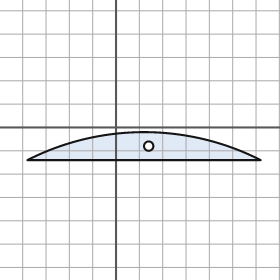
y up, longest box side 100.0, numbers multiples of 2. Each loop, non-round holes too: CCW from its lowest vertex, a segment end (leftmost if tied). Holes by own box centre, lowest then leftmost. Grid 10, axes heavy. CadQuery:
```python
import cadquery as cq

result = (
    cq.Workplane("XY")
    .moveTo(-38.0, -14.0)
    .lineTo(62.0, -14.0)
    .threePointArc((12.0, -2.0), (-38.0, -14.0))
    .close()
    .moveTo(14.0, -8.0)
    .circle(2.0)
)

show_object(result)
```